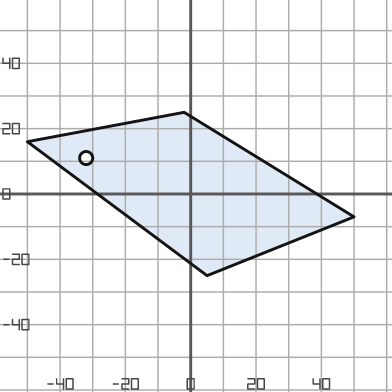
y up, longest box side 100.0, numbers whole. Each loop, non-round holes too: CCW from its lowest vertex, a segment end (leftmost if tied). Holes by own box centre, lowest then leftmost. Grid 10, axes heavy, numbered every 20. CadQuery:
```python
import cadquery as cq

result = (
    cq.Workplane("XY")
    .moveTo(5.0, -25.0)
    .lineTo(50.0, -7.0)
    .lineTo(-2.0, 25.0)
    .lineTo(-50.0, 16.0)
    .close()
    .moveTo(-32.0, 11.0)
    .circle(2.0)
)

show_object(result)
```